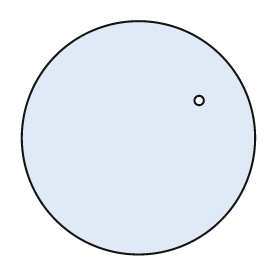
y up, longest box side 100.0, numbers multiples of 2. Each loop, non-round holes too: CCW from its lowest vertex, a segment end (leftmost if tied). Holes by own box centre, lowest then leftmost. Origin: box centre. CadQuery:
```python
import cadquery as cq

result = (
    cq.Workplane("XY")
    .moveTo(0.0, 0.0)
    .circle(50.0)
    .moveTo(26.0, 16.0)
    .circle(2.0)
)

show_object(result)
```